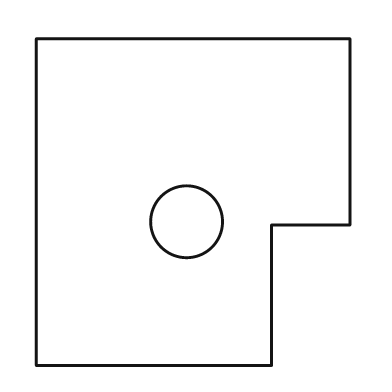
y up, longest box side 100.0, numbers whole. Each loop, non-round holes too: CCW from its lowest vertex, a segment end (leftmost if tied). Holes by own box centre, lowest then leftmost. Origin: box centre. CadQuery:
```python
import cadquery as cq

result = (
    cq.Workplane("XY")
    .moveTo(-48.0, -50.0)
    .lineTo(24.0, -50.0)
    .lineTo(24.0, -7.0)
    .lineTo(48.0, -7.0)
    .lineTo(48.0, 50.0)
    .lineTo(-48.0, 50.0)
    .close()
    .moveTo(-2.0, -6.0)
    .circle(11.0)
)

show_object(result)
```